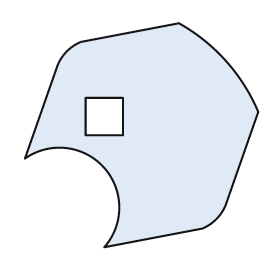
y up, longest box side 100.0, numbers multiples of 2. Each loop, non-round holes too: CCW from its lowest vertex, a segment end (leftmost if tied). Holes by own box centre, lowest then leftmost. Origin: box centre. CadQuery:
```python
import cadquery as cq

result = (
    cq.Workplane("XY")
    .moveTo(-16.0, -48.0)
    .lineTo(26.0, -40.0)
    .threePointArc((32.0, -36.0), (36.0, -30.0))
    .lineTo(50.0, 10.0)
    .threePointArc((36.0, 32.0), (16.0, 48.0))
    .lineTo(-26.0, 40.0)
    .threePointArc((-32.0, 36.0), (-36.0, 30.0))
    .lineTo(-50.0, -10.0)
    .threePointArc((-16.0, -14.0), (-16.0, -48.0))
    .close()
    .moveTo(-24.0, 0.0)
    .lineTo(-8.0, 0.0)
    .lineTo(-8.0, 16.0)
    .lineTo(-24.0, 16.0)
    .close()
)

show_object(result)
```